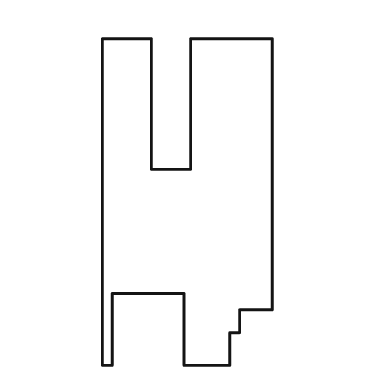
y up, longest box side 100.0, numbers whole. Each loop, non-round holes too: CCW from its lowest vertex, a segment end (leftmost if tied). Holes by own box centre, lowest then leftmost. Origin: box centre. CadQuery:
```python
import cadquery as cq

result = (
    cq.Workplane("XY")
    .moveTo(-26.0, -50.0)
    .lineTo(-23.0, -50.0)
    .lineTo(-23.0, -28.0)
    .lineTo(-1.0, -28.0)
    .lineTo(-1.0, -50.0)
    .lineTo(13.0, -50.0)
    .lineTo(13.0, -40.0)
    .lineTo(16.0, -40.0)
    .lineTo(16.0, -33.0)
    .lineTo(26.0, -33.0)
    .lineTo(26.0, 50.0)
    .lineTo(1.0, 50.0)
    .lineTo(1.0, 10.0)
    .lineTo(-11.0, 10.0)
    .lineTo(-11.0, 50.0)
    .lineTo(-26.0, 50.0)
    .close()
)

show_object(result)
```